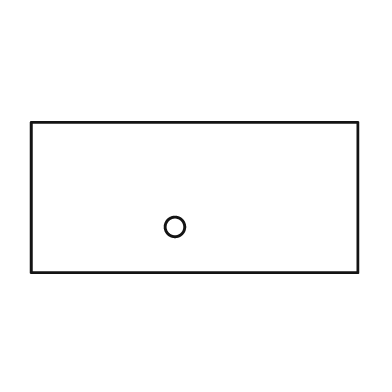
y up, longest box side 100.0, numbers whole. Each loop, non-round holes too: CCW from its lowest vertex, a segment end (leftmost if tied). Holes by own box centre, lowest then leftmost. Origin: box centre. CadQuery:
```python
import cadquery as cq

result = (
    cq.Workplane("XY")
    .moveTo(-50.0, -23.0)
    .lineTo(50.0, -23.0)
    .lineTo(50.0, 23.0)
    .lineTo(-50.0, 23.0)
    .close()
    .moveTo(-6.0, -9.0)
    .circle(3.0)
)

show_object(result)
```